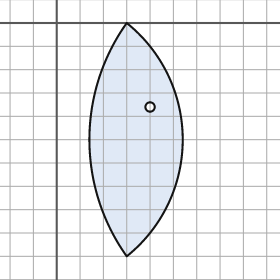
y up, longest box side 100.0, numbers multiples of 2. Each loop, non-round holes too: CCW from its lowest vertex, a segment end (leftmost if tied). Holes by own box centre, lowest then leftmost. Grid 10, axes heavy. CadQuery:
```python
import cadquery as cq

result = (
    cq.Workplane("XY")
    .moveTo(30.0, -100.0)
    .threePointArc((54.0, -50.0), (30.0, 0.0))
    .threePointArc((14.0, -50.0), (30.0, -100.0))
    .close()
    .moveTo(40.0, -36.0)
    .circle(2.0)
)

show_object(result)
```